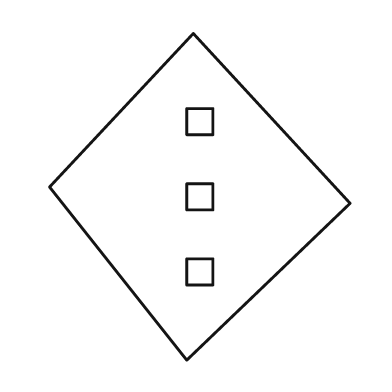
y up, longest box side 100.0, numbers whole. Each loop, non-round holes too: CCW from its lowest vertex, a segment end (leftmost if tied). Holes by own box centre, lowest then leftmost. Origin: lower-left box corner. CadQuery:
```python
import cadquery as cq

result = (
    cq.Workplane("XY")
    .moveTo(42.0, 0.0)
    .lineTo(92.0, 48.0)
    .lineTo(44.0, 100.0)
    .lineTo(0.0, 53.0)
    .close()
    .moveTo(42.0, 23.0)
    .lineTo(50.0, 23.0)
    .lineTo(50.0, 31.0)
    .lineTo(42.0, 31.0)
    .close()
    .moveTo(42.0, 46.0)
    .lineTo(50.0, 46.0)
    .lineTo(50.0, 54.0)
    .lineTo(42.0, 54.0)
    .close()
    .moveTo(42.0, 69.0)
    .lineTo(50.0, 69.0)
    .lineTo(50.0, 77.0)
    .lineTo(42.0, 77.0)
    .close()
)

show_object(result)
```